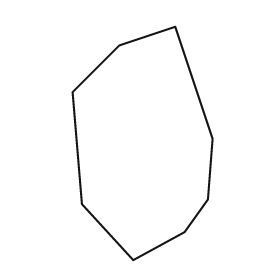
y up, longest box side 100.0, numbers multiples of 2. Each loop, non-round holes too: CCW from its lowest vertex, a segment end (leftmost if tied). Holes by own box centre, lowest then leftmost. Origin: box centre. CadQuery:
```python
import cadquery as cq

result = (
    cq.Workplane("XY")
    .moveTo(-4.0, -50.0)
    .lineTo(18.0, -38.0)
    .lineTo(28.0, -24.0)
    .lineTo(30.0, 2.0)
    .lineTo(14.0, 50.0)
    .lineTo(-10.0, 42.0)
    .lineTo(-30.0, 22.0)
    .lineTo(-26.0, -26.0)
    .close()
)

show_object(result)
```